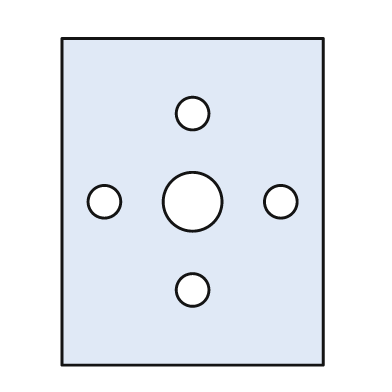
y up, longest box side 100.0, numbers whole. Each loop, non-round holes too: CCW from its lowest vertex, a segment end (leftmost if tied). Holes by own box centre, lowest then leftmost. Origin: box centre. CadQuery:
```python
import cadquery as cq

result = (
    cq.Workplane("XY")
    .moveTo(-40.0, -50.0)
    .lineTo(40.0, -50.0)
    .lineTo(40.0, 50.0)
    .lineTo(-40.0, 50.0)
    .close()
    .moveTo(0.0, -27.0)
    .circle(5.0)
    .moveTo(-27.0, 0.0)
    .circle(5.0)
    .moveTo(0.0, 0.0)
    .circle(9.0)
    .moveTo(27.0, 0.0)
    .circle(5.0)
    .moveTo(0.0, 27.0)
    .circle(5.0)
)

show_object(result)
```